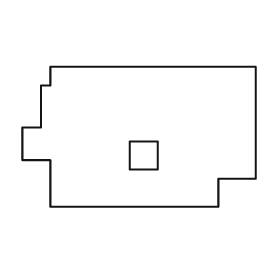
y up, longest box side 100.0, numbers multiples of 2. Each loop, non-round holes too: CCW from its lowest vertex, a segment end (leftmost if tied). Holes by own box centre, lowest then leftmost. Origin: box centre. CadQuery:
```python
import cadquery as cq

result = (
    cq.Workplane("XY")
    .moveTo(-38.0, -30.0)
    .lineTo(34.0, -30.0)
    .lineTo(34.0, -18.0)
    .lineTo(50.0, -18.0)
    .lineTo(50.0, 30.0)
    .lineTo(-38.0, 30.0)
    .lineTo(-38.0, 22.0)
    .lineTo(-42.0, 22.0)
    .lineTo(-42.0, 4.0)
    .lineTo(-50.0, 4.0)
    .lineTo(-50.0, -10.0)
    .lineTo(-38.0, -10.0)
    .close()
    .moveTo(-4.0, -14.0)
    .lineTo(8.0, -14.0)
    .lineTo(8.0, -2.0)
    .lineTo(-4.0, -2.0)
    .close()
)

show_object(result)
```